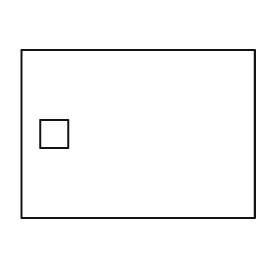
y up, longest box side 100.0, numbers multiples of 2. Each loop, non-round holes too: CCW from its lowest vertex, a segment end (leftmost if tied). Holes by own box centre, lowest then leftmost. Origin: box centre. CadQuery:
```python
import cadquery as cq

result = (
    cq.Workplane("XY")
    .moveTo(-50.0, -36.0)
    .lineTo(50.0, -36.0)
    .lineTo(50.0, 36.0)
    .lineTo(-50.0, 36.0)
    .close()
    .moveTo(-42.0, -6.0)
    .lineTo(-30.0, -6.0)
    .lineTo(-30.0, 6.0)
    .lineTo(-42.0, 6.0)
    .close()
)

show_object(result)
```